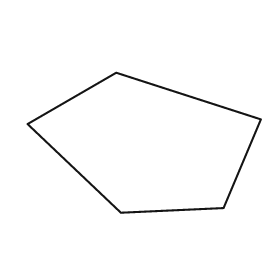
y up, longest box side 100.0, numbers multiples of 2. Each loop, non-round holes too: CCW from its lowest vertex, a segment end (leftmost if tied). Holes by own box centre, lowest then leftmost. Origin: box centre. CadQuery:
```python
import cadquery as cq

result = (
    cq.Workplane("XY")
    .moveTo(-10.0, -30.0)
    .lineTo(34.0, -28.0)
    .lineTo(50.0, 10.0)
    .lineTo(-12.0, 30.0)
    .lineTo(-50.0, 8.0)
    .close()
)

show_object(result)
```